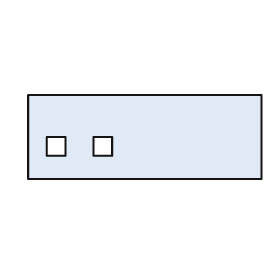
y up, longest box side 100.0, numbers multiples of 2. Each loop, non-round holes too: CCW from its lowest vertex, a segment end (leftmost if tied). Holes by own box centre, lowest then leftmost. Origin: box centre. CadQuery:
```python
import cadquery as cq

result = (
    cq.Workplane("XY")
    .moveTo(-50.0, -18.0)
    .lineTo(50.0, -18.0)
    .lineTo(50.0, 18.0)
    .lineTo(-50.0, 18.0)
    .close()
    .moveTo(-42.0, -8.0)
    .lineTo(-34.0, -8.0)
    .lineTo(-34.0, 0.0)
    .lineTo(-42.0, 0.0)
    .close()
    .moveTo(-22.0, -8.0)
    .lineTo(-14.0, -8.0)
    .lineTo(-14.0, 0.0)
    .lineTo(-22.0, 0.0)
    .close()
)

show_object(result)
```